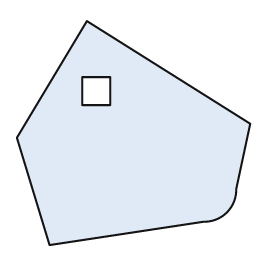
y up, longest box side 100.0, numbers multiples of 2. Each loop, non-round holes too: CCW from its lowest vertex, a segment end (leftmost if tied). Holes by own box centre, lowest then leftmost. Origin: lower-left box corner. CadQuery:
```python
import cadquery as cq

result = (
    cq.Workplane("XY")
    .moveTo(14.0, 0.0)
    .lineTo(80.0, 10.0)
    .threePointArc((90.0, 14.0), (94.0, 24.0))
    .lineTo(100.0, 52.0)
    .lineTo(30.0, 96.0)
    .lineTo(0.0, 46.0)
    .close()
    .moveTo(28.0, 60.0)
    .lineTo(40.0, 60.0)
    .lineTo(40.0, 72.0)
    .lineTo(28.0, 72.0)
    .close()
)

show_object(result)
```